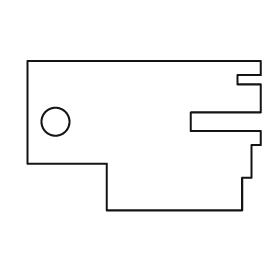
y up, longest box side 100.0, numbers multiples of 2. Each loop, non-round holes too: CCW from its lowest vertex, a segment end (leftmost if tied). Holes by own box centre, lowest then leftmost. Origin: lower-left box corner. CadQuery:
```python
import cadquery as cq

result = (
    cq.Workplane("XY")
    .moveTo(34.0, 0.0)
    .lineTo(92.0, 0.0)
    .lineTo(92.0, 14.0)
    .lineTo(96.0, 14.0)
    .lineTo(96.0, 28.0)
    .lineTo(100.0, 28.0)
    .lineTo(100.0, 34.0)
    .lineTo(70.0, 34.0)
    .lineTo(70.0, 42.0)
    .lineTo(100.0, 42.0)
    .lineTo(100.0, 54.0)
    .lineTo(90.0, 54.0)
    .lineTo(90.0, 58.0)
    .lineTo(100.0, 58.0)
    .lineTo(100.0, 64.0)
    .lineTo(0.0, 64.0)
    .lineTo(0.0, 20.0)
    .lineTo(34.0, 20.0)
    .close()
    .moveTo(12.0, 38.0)
    .circle(6.0)
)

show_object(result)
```